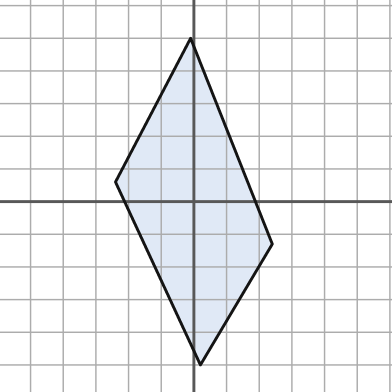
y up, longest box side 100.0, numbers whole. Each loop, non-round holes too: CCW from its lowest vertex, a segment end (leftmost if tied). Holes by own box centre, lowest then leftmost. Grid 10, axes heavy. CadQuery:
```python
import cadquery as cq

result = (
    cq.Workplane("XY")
    .moveTo(2.0, -50.0)
    .lineTo(24.0, -13.0)
    .lineTo(-1.0, 50.0)
    .lineTo(-24.0, 6.0)
    .close()
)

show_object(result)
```